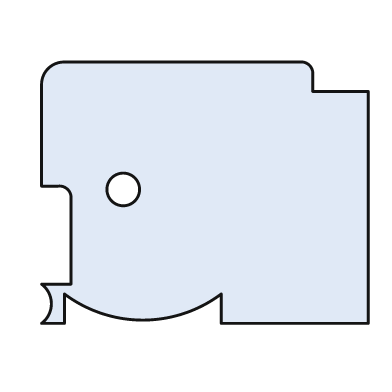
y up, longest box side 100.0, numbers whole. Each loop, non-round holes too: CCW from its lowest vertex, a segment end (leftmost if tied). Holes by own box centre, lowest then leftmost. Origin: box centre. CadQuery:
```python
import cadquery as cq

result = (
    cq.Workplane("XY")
    .moveTo(-50.0, -40.0)
    .lineTo(-43.0, -40.0)
    .lineTo(-43.0, -31.0)
    .threePointArc((-19.0, -39.0), (5.0, -31.0))
    .lineTo(5.0, -40.0)
    .lineTo(50.0, -40.0)
    .lineTo(50.0, 31.0)
    .lineTo(33.0, 31.0)
    .lineTo(33.0, 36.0)
    .threePointArc((32.0, 39.0), (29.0, 40.0))
    .lineTo(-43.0, 40.0)
    .threePointArc((-48.0, 38.0), (-50.0, 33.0))
    .lineTo(-50.0, 2.0)
    .lineTo(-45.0, 2.0)
    .threePointArc((-42.0, 1.0), (-41.0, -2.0))
    .lineTo(-41.0, -28.0)
    .lineTo(-50.0, -28.0)
    .threePointArc((-47.0, -34.0), (-50.0, -40.0))
    .close()
    .moveTo(-25.0, 1.0)
    .circle(5.0)
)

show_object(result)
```